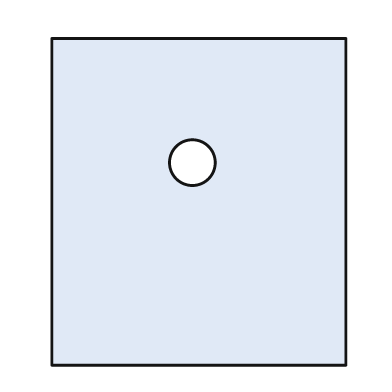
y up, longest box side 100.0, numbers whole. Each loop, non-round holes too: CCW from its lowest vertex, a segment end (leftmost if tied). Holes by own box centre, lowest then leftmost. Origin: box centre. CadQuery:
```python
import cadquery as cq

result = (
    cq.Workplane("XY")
    .moveTo(-45.0, -50.0)
    .lineTo(45.0, -50.0)
    .lineTo(45.0, 50.0)
    .lineTo(-45.0, 50.0)
    .close()
    .moveTo(-2.0, 12.0)
    .circle(7.0)
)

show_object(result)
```